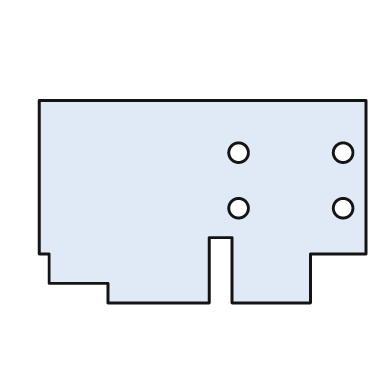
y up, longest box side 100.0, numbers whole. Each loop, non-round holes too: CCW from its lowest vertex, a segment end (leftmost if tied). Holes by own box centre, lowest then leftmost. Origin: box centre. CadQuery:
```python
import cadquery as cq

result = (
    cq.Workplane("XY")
    .moveTo(-29.0, -31.0)
    .lineTo(2.0, -31.0)
    .lineTo(2.0, -11.0)
    .lineTo(9.0, -11.0)
    .lineTo(9.0, -31.0)
    .lineTo(33.0, -31.0)
    .lineTo(33.0, -16.0)
    .lineTo(50.0, -16.0)
    .lineTo(50.0, 31.0)
    .lineTo(-50.0, 31.0)
    .lineTo(-50.0, -16.0)
    .lineTo(-47.0, -16.0)
    .lineTo(-47.0, -25.0)
    .lineTo(-29.0, -25.0)
    .close()
    .moveTo(11.0, -2.0)
    .circle(3.0)
    .moveTo(43.0, -2.0)
    .circle(3.0)
    .moveTo(11.0, 15.0)
    .circle(3.0)
    .moveTo(43.0, 15.0)
    .circle(3.0)
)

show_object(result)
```